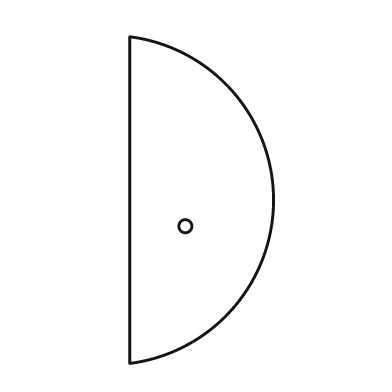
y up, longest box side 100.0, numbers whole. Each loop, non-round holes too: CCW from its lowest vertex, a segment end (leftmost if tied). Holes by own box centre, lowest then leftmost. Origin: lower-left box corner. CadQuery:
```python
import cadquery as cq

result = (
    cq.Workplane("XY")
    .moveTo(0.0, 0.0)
    .threePointArc((44.0, 50.0), (0.0, 100.0))
    .close()
    .moveTo(17.0, 42.0)
    .circle(2.0)
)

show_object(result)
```